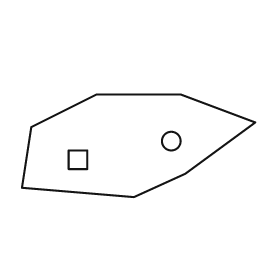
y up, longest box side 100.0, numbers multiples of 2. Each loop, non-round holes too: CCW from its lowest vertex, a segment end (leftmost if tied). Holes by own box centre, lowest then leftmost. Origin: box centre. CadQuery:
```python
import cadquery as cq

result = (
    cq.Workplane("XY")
    .moveTo(-2.0, -22.0)
    .lineTo(20.0, -12.0)
    .lineTo(50.0, 10.0)
    .lineTo(18.0, 22.0)
    .lineTo(-18.0, 22.0)
    .lineTo(-46.0, 8.0)
    .lineTo(-50.0, -18.0)
    .close()
    .moveTo(-30.0, -10.0)
    .lineTo(-22.0, -10.0)
    .lineTo(-22.0, -2.0)
    .lineTo(-30.0, -2.0)
    .close()
    .moveTo(14.0, 2.0)
    .circle(4.0)
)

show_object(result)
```